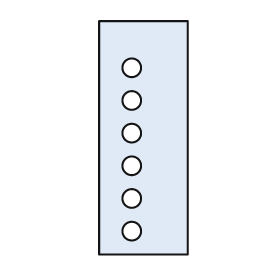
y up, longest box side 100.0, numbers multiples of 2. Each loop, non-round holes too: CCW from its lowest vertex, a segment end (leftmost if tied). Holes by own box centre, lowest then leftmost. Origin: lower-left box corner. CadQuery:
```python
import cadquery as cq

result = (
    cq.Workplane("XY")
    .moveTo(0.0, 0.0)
    .lineTo(38.0, 0.0)
    .lineTo(38.0, 100.0)
    .lineTo(0.0, 100.0)
    .close()
    .moveTo(14.0, 10.0)
    .circle(4.0)
    .moveTo(14.0, 24.0)
    .circle(4.0)
    .moveTo(14.0, 38.0)
    .circle(4.0)
    .moveTo(14.0, 52.0)
    .circle(4.0)
    .moveTo(14.0, 66.0)
    .circle(4.0)
    .moveTo(14.0, 80.0)
    .circle(4.0)
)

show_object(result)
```